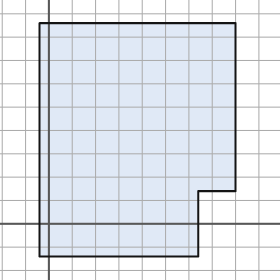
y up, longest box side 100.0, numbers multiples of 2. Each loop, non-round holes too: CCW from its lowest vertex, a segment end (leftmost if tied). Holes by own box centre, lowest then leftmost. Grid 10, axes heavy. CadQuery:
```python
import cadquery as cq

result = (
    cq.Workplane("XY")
    .moveTo(-4.0, -14.0)
    .lineTo(64.0, -14.0)
    .lineTo(64.0, 14.0)
    .lineTo(80.0, 14.0)
    .lineTo(80.0, 86.0)
    .lineTo(-4.0, 86.0)
    .close()
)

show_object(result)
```